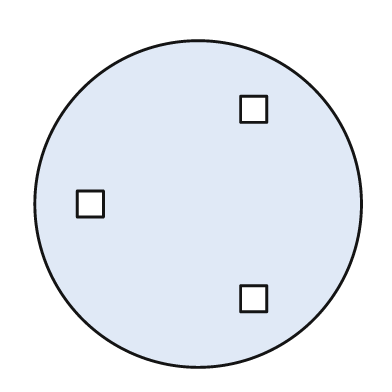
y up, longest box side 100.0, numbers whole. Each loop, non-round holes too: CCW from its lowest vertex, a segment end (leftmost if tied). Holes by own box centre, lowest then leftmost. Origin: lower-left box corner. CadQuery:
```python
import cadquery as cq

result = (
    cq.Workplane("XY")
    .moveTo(50.0, 50.0)
    .circle(50.0)
    .moveTo(63.0, 17.0)
    .lineTo(71.0, 17.0)
    .lineTo(71.0, 25.0)
    .lineTo(63.0, 25.0)
    .close()
    .moveTo(13.0, 46.0)
    .lineTo(21.0, 46.0)
    .lineTo(21.0, 54.0)
    .lineTo(13.0, 54.0)
    .close()
    .moveTo(63.0, 75.0)
    .lineTo(71.0, 75.0)
    .lineTo(71.0, 83.0)
    .lineTo(63.0, 83.0)
    .close()
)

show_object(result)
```